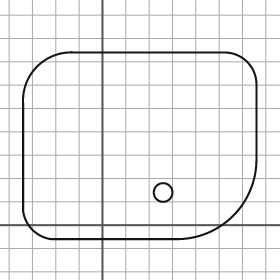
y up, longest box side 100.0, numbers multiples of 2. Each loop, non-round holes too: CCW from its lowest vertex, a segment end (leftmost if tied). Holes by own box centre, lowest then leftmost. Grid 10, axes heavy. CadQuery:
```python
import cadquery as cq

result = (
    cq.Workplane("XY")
    .moveTo(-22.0, -6.0)
    .lineTo(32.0, -6.0)
    .threePointArc((56.0, 4.0), (66.0, 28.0))
    .lineTo(66.0, 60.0)
    .threePointArc((62.0, 70.0), (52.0, 74.0))
    .lineTo(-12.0, 74.0)
    .threePointArc((-28.0, 68.0), (-34.0, 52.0))
    .lineTo(-34.0, 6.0)
    .threePointArc((-30.0, -2.0), (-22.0, -6.0))
    .close()
    .moveTo(26.0, 14.0)
    .circle(4.0)
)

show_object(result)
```